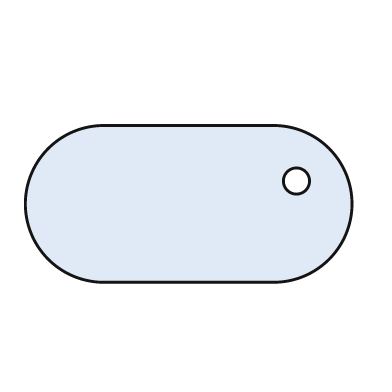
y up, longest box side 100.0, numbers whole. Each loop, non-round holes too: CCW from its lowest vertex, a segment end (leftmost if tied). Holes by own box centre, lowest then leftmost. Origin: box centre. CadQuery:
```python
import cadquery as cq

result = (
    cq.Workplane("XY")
    .moveTo(-26.0, -24.0)
    .lineTo(26.0, -24.0)
    .threePointArc((50.0, 0.0), (26.0, 24.0))
    .lineTo(-26.0, 24.0)
    .threePointArc((-50.0, 0.0), (-26.0, -24.0))
    .close()
    .moveTo(33.0, 7.0)
    .circle(4.0)
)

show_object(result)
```